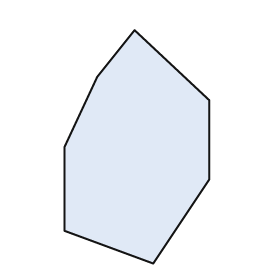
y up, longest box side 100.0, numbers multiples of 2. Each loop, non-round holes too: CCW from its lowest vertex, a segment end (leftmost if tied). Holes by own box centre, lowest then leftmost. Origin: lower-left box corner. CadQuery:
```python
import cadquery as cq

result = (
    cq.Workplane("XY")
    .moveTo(38.0, 0.0)
    .lineTo(62.0, 36.0)
    .lineTo(62.0, 70.0)
    .lineTo(30.0, 100.0)
    .lineTo(14.0, 80.0)
    .lineTo(0.0, 50.0)
    .lineTo(0.0, 14.0)
    .close()
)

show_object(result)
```